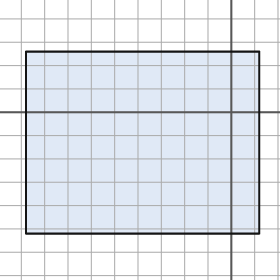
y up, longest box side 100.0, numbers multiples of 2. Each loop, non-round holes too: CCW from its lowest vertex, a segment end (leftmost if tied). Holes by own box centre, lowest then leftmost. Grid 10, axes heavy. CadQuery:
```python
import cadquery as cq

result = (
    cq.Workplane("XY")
    .moveTo(-88.0, -52.0)
    .lineTo(12.0, -52.0)
    .lineTo(12.0, 26.0)
    .lineTo(-88.0, 26.0)
    .close()
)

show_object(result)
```